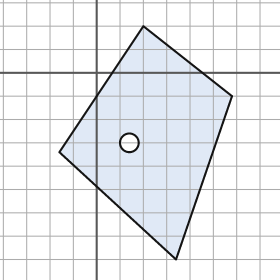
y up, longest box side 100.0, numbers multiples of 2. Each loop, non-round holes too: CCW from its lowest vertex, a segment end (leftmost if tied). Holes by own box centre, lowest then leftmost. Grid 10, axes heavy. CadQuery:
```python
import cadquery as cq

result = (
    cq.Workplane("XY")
    .moveTo(34.0, -80.0)
    .lineTo(58.0, -10.0)
    .lineTo(20.0, 20.0)
    .lineTo(-16.0, -34.0)
    .close()
    .moveTo(14.0, -30.0)
    .circle(4.0)
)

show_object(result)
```